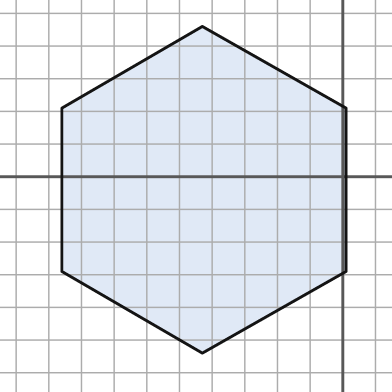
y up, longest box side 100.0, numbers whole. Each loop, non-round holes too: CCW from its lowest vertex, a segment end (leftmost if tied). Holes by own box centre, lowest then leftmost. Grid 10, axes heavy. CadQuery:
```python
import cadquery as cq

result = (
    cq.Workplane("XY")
    .moveTo(-43.0, -54.0)
    .lineTo(1.0, -29.0)
    .lineTo(1.0, 21.0)
    .lineTo(-43.0, 46.0)
    .lineTo(-86.0, 21.0)
    .lineTo(-86.0, -29.0)
    .close()
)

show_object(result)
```